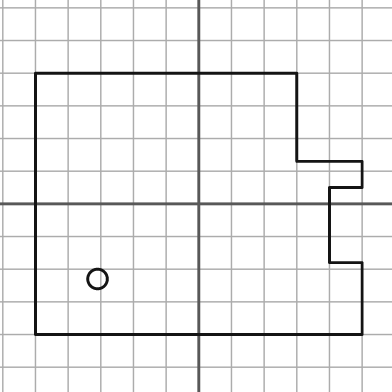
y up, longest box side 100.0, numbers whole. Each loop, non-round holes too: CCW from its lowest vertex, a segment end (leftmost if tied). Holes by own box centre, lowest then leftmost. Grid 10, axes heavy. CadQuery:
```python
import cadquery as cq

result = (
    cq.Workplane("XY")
    .moveTo(-50.0, -40.0)
    .lineTo(50.0, -40.0)
    .lineTo(50.0, -18.0)
    .lineTo(40.0, -18.0)
    .lineTo(40.0, 5.0)
    .lineTo(50.0, 5.0)
    .lineTo(50.0, 13.0)
    .lineTo(30.0, 13.0)
    .lineTo(30.0, 40.0)
    .lineTo(-50.0, 40.0)
    .close()
    .moveTo(-31.0, -23.0)
    .circle(3.0)
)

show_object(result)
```